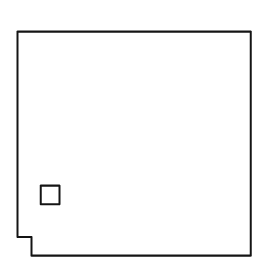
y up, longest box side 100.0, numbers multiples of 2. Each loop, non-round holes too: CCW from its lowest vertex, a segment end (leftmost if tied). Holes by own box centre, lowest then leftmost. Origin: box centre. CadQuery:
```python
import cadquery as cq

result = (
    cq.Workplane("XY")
    .moveTo(-44.0, -48.0)
    .lineTo(50.0, -48.0)
    .lineTo(50.0, 48.0)
    .lineTo(-50.0, 48.0)
    .lineTo(-50.0, -40.0)
    .lineTo(-44.0, -40.0)
    .close()
    .moveTo(-40.0, -26.0)
    .lineTo(-32.0, -26.0)
    .lineTo(-32.0, -18.0)
    .lineTo(-40.0, -18.0)
    .close()
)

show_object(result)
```